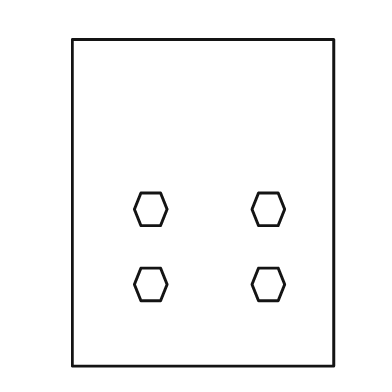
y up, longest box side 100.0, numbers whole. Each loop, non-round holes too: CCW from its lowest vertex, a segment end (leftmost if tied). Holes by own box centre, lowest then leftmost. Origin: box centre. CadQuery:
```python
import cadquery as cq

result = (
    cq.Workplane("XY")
    .moveTo(-40.0, -50.0)
    .lineTo(40.0, -50.0)
    .lineTo(40.0, 50.0)
    .lineTo(-40.0, 50.0)
    .close()
    .moveTo(-19.0, -30.0)
    .lineTo(-13.0, -30.0)
    .lineTo(-11.0, -25.0)
    .lineTo(-13.0, -20.0)
    .lineTo(-19.0, -20.0)
    .lineTo(-21.0, -25.0)
    .close()
    .moveTo(17.0, -30.0)
    .lineTo(23.0, -30.0)
    .lineTo(25.0, -25.0)
    .lineTo(23.0, -20.0)
    .lineTo(17.0, -20.0)
    .lineTo(15.0, -25.0)
    .close()
    .moveTo(-19.0, -7.0)
    .lineTo(-13.0, -7.0)
    .lineTo(-11.0, -2.0)
    .lineTo(-13.0, 3.0)
    .lineTo(-19.0, 3.0)
    .lineTo(-21.0, -2.0)
    .close()
    .moveTo(17.0, -7.0)
    .lineTo(23.0, -7.0)
    .lineTo(25.0, -2.0)
    .lineTo(23.0, 3.0)
    .lineTo(17.0, 3.0)
    .lineTo(15.0, -2.0)
    .close()
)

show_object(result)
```